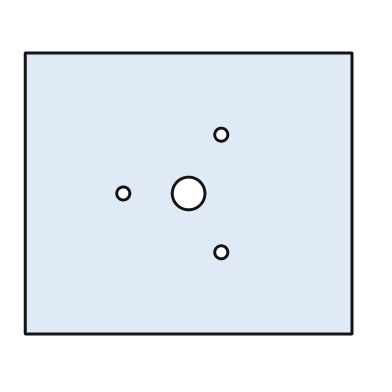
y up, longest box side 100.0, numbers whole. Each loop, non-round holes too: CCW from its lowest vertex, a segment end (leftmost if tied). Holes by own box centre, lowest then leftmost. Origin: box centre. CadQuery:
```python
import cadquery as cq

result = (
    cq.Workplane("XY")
    .moveTo(-50.0, -43.0)
    .lineTo(50.0, -43.0)
    .lineTo(50.0, 43.0)
    .lineTo(-50.0, 43.0)
    .close()
    .moveTo(10.0, -18.0)
    .circle(2.0)
    .moveTo(-20.0, 0.0)
    .circle(2.0)
    .moveTo(0.0, 0.0)
    .circle(5.0)
    .moveTo(10.0, 18.0)
    .circle(2.0)
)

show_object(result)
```